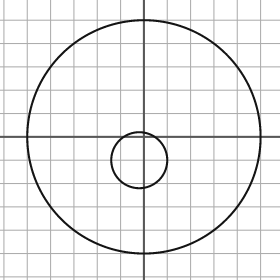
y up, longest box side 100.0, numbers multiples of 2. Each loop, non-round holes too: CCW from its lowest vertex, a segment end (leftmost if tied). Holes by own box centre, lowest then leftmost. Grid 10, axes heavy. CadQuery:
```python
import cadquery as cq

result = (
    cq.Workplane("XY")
    .moveTo(0.0, 0.0)
    .circle(50.0)
    .moveTo(-2.0, -10.0)
    .circle(12.0)
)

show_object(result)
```